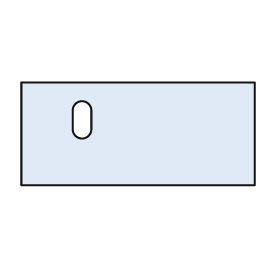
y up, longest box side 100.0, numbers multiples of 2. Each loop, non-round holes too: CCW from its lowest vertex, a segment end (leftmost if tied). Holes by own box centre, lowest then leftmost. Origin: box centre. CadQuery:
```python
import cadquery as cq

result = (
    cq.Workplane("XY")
    .moveTo(-50.0, -22.0)
    .lineTo(50.0, -22.0)
    .lineTo(50.0, 22.0)
    .lineTo(-50.0, 22.0)
    .close()
    .moveTo(-28.0, 2.0)
    .threePointArc((-24.0, -2.0), (-20.0, 2.0))
    .lineTo(-20.0, 10.0)
    .threePointArc((-24.0, 14.0), (-28.0, 10.0))
    .close()
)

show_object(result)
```